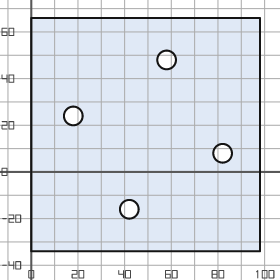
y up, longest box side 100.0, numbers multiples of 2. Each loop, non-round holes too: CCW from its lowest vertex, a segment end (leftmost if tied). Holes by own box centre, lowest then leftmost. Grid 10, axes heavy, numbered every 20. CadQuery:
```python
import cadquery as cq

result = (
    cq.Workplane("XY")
    .moveTo(0.0, -34.0)
    .lineTo(98.0, -34.0)
    .lineTo(98.0, 66.0)
    .lineTo(0.0, 66.0)
    .close()
    .moveTo(42.0, -16.0)
    .circle(4.0)
    .moveTo(82.0, 8.0)
    .circle(4.0)
    .moveTo(18.0, 24.0)
    .circle(4.0)
    .moveTo(58.0, 48.0)
    .circle(4.0)
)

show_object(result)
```